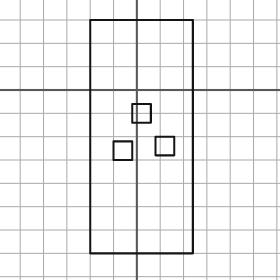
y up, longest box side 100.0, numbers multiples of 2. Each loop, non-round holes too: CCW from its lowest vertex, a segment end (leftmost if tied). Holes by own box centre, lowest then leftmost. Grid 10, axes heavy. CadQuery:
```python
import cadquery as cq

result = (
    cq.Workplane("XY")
    .moveTo(-20.0, -70.0)
    .lineTo(24.0, -70.0)
    .lineTo(24.0, 30.0)
    .lineTo(-20.0, 30.0)
    .close()
    .moveTo(-10.0, -30.0)
    .lineTo(-2.0, -30.0)
    .lineTo(-2.0, -22.0)
    .lineTo(-10.0, -22.0)
    .close()
    .moveTo(8.0, -28.0)
    .lineTo(16.0, -28.0)
    .lineTo(16.0, -20.0)
    .lineTo(8.0, -20.0)
    .close()
    .moveTo(-2.0, -14.0)
    .lineTo(6.0, -14.0)
    .lineTo(6.0, -6.0)
    .lineTo(-2.0, -6.0)
    .close()
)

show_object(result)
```